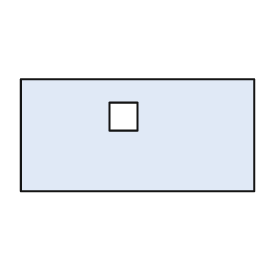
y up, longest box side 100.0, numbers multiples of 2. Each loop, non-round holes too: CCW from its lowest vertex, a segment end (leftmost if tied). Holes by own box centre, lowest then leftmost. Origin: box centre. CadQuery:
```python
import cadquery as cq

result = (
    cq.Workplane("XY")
    .moveTo(-50.0, -24.0)
    .lineTo(50.0, -24.0)
    .lineTo(50.0, 24.0)
    .lineTo(-50.0, 24.0)
    .close()
    .moveTo(-12.0, 2.0)
    .lineTo(0.0, 2.0)
    .lineTo(0.0, 14.0)
    .lineTo(-12.0, 14.0)
    .close()
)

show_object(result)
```